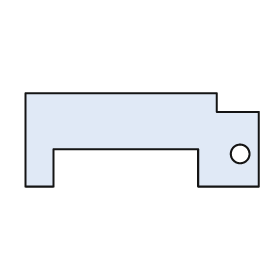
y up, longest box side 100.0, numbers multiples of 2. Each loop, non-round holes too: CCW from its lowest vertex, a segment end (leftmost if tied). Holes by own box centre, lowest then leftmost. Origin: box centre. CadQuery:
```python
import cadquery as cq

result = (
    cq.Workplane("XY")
    .moveTo(-50.0, -20.0)
    .lineTo(-38.0, -20.0)
    .lineTo(-38.0, -4.0)
    .lineTo(24.0, -4.0)
    .lineTo(24.0, -20.0)
    .lineTo(50.0, -20.0)
    .lineTo(50.0, 12.0)
    .lineTo(32.0, 12.0)
    .lineTo(32.0, 20.0)
    .lineTo(-50.0, 20.0)
    .close()
    .moveTo(42.0, -6.0)
    .circle(4.0)
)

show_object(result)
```